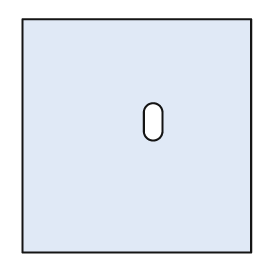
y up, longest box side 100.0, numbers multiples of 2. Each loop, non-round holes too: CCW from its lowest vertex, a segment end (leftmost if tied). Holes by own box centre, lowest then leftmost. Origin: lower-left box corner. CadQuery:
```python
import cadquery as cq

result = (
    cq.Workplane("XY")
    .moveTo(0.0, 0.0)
    .lineTo(98.0, 0.0)
    .lineTo(98.0, 100.0)
    .lineTo(0.0, 100.0)
    .close()
    .moveTo(52.0, 52.0)
    .threePointArc((56.0, 48.0), (60.0, 52.0))
    .lineTo(60.0, 60.0)
    .threePointArc((56.0, 64.0), (52.0, 60.0))
    .close()
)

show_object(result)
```